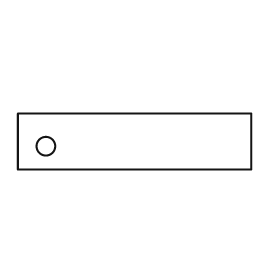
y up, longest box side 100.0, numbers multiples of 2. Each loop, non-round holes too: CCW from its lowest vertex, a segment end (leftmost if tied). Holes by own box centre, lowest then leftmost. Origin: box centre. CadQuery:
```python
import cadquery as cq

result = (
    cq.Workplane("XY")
    .moveTo(-50.0, -12.0)
    .lineTo(50.0, -12.0)
    .lineTo(50.0, 12.0)
    .lineTo(-50.0, 12.0)
    .close()
    .moveTo(-38.0, -2.0)
    .circle(4.0)
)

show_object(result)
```